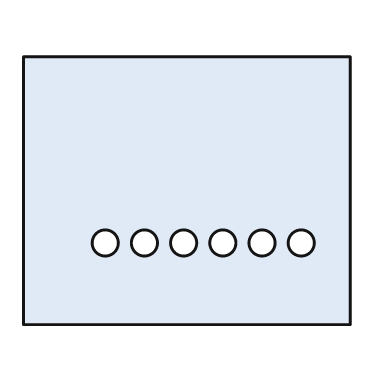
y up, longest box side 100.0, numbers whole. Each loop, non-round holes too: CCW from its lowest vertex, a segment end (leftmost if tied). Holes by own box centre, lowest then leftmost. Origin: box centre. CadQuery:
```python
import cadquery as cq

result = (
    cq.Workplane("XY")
    .moveTo(-50.0, -41.0)
    .lineTo(50.0, -41.0)
    .lineTo(50.0, 41.0)
    .lineTo(-50.0, 41.0)
    .close()
    .moveTo(-25.0, -16.0)
    .circle(4.0)
    .moveTo(-13.0, -16.0)
    .circle(4.0)
    .moveTo(-1.0, -16.0)
    .circle(4.0)
    .moveTo(11.0, -16.0)
    .circle(4.0)
    .moveTo(23.0, -16.0)
    .circle(4.0)
    .moveTo(35.0, -16.0)
    .circle(4.0)
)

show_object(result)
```